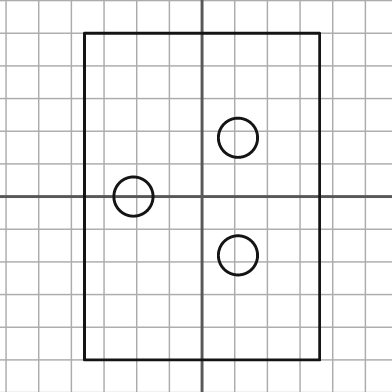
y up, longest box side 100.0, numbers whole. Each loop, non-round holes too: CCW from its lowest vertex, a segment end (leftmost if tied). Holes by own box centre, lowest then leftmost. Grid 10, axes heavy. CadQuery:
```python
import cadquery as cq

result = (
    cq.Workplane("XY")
    .moveTo(-36.0, -50.0)
    .lineTo(36.0, -50.0)
    .lineTo(36.0, 50.0)
    .lineTo(-36.0, 50.0)
    .close()
    .moveTo(11.0, -18.0)
    .circle(6.0)
    .moveTo(-21.0, 0.0)
    .circle(6.0)
    .moveTo(11.0, 18.0)
    .circle(6.0)
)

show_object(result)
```